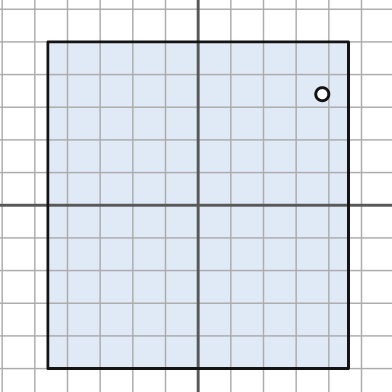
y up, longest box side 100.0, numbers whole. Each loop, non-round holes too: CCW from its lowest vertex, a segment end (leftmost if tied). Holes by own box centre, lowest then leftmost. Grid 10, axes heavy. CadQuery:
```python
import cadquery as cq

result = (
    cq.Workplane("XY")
    .moveTo(-46.0, -50.0)
    .lineTo(46.0, -50.0)
    .lineTo(46.0, 50.0)
    .lineTo(-46.0, 50.0)
    .close()
    .moveTo(38.0, 34.0)
    .circle(2.0)
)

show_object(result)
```